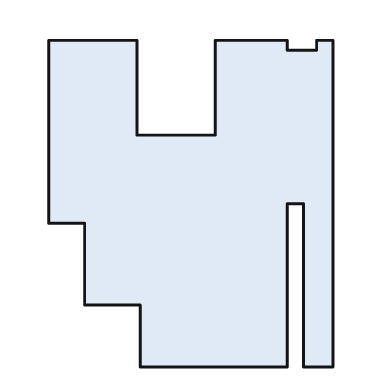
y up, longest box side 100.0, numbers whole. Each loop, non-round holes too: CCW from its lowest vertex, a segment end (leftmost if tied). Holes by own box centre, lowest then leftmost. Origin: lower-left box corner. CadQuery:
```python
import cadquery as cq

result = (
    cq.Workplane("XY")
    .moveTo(28.0, 0.0)
    .lineTo(73.0, 0.0)
    .lineTo(73.0, 50.0)
    .lineTo(78.0, 50.0)
    .lineTo(78.0, 0.0)
    .lineTo(87.0, 0.0)
    .lineTo(87.0, 100.0)
    .lineTo(82.0, 100.0)
    .lineTo(82.0, 97.0)
    .lineTo(73.0, 97.0)
    .lineTo(73.0, 100.0)
    .lineTo(51.0, 100.0)
    .lineTo(51.0, 71.0)
    .lineTo(27.0, 71.0)
    .lineTo(27.0, 100.0)
    .lineTo(0.0, 100.0)
    .lineTo(0.0, 44.0)
    .lineTo(11.0, 44.0)
    .lineTo(11.0, 19.0)
    .lineTo(28.0, 19.0)
    .close()
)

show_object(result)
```